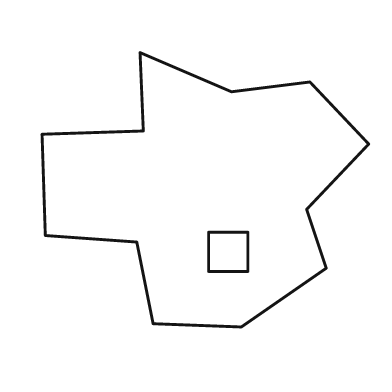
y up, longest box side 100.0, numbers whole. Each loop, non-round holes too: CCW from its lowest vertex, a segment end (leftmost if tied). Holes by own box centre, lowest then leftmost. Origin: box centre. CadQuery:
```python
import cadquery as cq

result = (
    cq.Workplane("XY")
    .moveTo(11.0, -42.0)
    .lineTo(37.0, -24.0)
    .lineTo(31.0, -6.0)
    .lineTo(50.0, 14.0)
    .lineTo(32.0, 33.0)
    .lineTo(8.0, 30.0)
    .lineTo(-20.0, 42.0)
    .lineTo(-19.0, 18.0)
    .lineTo(-50.0, 17.0)
    .lineTo(-49.0, -14.0)
    .lineTo(-21.0, -16.0)
    .lineTo(-16.0, -41.0)
    .close()
    .moveTo(1.0, -25.0)
    .lineTo(13.0, -25.0)
    .lineTo(13.0, -13.0)
    .lineTo(1.0, -13.0)
    .close()
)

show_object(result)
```